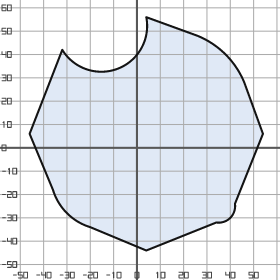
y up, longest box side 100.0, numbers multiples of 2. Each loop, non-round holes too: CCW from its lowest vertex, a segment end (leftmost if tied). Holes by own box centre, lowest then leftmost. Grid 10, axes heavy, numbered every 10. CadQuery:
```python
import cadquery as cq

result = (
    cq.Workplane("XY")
    .moveTo(4.0, -44.0)
    .lineTo(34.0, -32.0)
    .threePointArc((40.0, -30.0), (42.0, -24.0))
    .lineTo(54.0, 6.0)
    .lineTo(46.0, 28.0)
    .threePointArc((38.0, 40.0), (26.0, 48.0))
    .lineTo(4.0, 56.0)
    .threePointArc((-8.0, 34.0), (-32.0, 42.0))
    .lineTo(-46.0, 6.0)
    .lineTo(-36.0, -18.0)
    .threePointArc((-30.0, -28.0), (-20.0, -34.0))
    .close()
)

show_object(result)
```